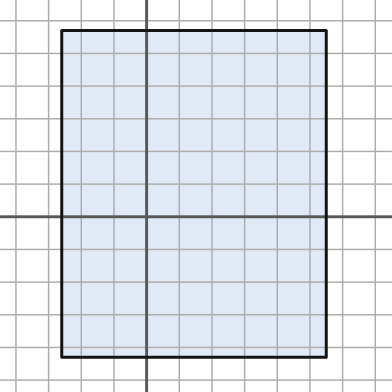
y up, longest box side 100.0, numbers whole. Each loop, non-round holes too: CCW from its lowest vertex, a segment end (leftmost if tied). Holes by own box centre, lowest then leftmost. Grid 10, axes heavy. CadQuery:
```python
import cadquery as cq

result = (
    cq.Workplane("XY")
    .moveTo(-26.0, -43.0)
    .lineTo(55.0, -43.0)
    .lineTo(55.0, 57.0)
    .lineTo(-26.0, 57.0)
    .close()
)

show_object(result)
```